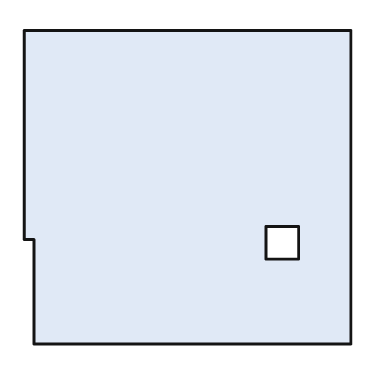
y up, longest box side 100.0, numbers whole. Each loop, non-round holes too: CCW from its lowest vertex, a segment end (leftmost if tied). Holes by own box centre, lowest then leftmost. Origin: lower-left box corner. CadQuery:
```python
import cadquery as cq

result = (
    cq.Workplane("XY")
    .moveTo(3.0, 0.0)
    .lineTo(100.0, 0.0)
    .lineTo(100.0, 96.0)
    .lineTo(0.0, 96.0)
    .lineTo(0.0, 32.0)
    .lineTo(3.0, 32.0)
    .close()
    .moveTo(74.0, 26.0)
    .lineTo(84.0, 26.0)
    .lineTo(84.0, 36.0)
    .lineTo(74.0, 36.0)
    .close()
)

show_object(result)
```